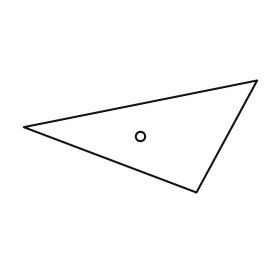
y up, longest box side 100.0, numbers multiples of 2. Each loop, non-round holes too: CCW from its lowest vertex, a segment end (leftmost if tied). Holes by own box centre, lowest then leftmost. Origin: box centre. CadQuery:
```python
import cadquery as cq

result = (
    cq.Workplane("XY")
    .moveTo(24.0, -24.0)
    .lineTo(50.0, 24.0)
    .lineTo(-50.0, 4.0)
    .close()
    .moveTo(0.0, 0.0)
    .circle(2.0)
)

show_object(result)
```